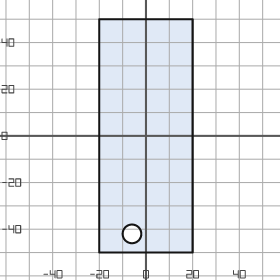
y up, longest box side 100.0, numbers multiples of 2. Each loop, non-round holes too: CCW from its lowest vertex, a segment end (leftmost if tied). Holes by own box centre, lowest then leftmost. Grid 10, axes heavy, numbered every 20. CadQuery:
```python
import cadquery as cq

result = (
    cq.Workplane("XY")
    .moveTo(-20.0, -50.0)
    .lineTo(20.0, -50.0)
    .lineTo(20.0, 50.0)
    .lineTo(-20.0, 50.0)
    .close()
    .moveTo(-6.0, -42.0)
    .circle(4.0)
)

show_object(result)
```